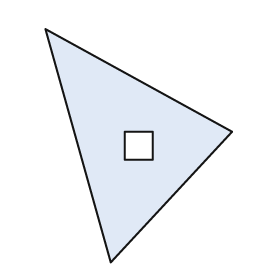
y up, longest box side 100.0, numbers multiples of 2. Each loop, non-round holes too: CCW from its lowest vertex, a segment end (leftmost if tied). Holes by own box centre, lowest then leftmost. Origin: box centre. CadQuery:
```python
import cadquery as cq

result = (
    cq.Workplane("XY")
    .moveTo(-12.0, -50.0)
    .lineTo(40.0, 6.0)
    .lineTo(-40.0, 50.0)
    .close()
    .moveTo(-6.0, -6.0)
    .lineTo(6.0, -6.0)
    .lineTo(6.0, 6.0)
    .lineTo(-6.0, 6.0)
    .close()
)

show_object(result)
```